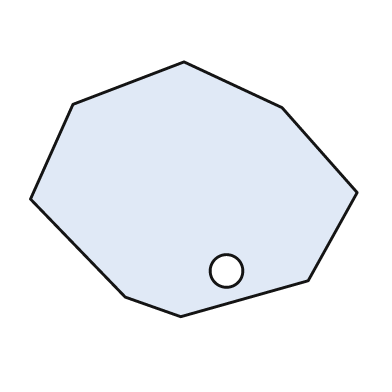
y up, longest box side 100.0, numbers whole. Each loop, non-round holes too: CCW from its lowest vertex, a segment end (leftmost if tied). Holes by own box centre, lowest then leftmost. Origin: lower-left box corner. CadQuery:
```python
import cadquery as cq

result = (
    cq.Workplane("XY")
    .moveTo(46.0, 0.0)
    .lineTo(85.0, 11.0)
    .lineTo(100.0, 38.0)
    .lineTo(77.0, 64.0)
    .lineTo(47.0, 78.0)
    .lineTo(13.0, 65.0)
    .lineTo(0.0, 36.0)
    .lineTo(29.0, 6.0)
    .close()
    .moveTo(60.0, 14.0)
    .circle(5.0)
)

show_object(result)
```